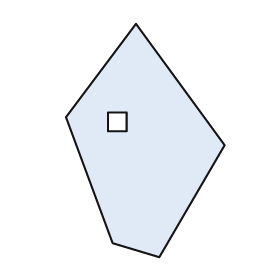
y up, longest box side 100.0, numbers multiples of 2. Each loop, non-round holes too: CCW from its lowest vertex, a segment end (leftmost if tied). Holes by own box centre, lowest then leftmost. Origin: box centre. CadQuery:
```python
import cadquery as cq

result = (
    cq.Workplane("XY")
    .moveTo(6.0, -50.0)
    .lineTo(34.0, -2.0)
    .lineTo(-4.0, 50.0)
    .lineTo(-34.0, 10.0)
    .lineTo(-14.0, -44.0)
    .close()
    .moveTo(-16.0, 4.0)
    .lineTo(-8.0, 4.0)
    .lineTo(-8.0, 12.0)
    .lineTo(-16.0, 12.0)
    .close()
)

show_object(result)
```